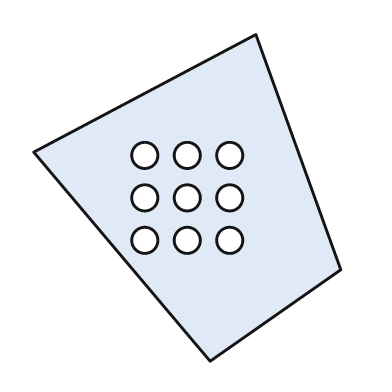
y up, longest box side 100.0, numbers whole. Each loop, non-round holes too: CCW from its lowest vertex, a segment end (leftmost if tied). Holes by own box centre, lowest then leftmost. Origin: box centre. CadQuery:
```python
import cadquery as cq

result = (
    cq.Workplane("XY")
    .moveTo(7.0, -50.0)
    .lineTo(47.0, -22.0)
    .lineTo(21.0, 50.0)
    .lineTo(-47.0, 14.0)
    .close()
    .moveTo(-13.0, -13.0)
    .circle(4.0)
    .moveTo(0.0, -13.0)
    .circle(4.0)
    .moveTo(13.0, -13.0)
    .circle(4.0)
    .moveTo(-13.0, 0.0)
    .circle(4.0)
    .moveTo(0.0, 0.0)
    .circle(4.0)
    .moveTo(13.0, 0.0)
    .circle(4.0)
    .moveTo(-13.0, 13.0)
    .circle(4.0)
    .moveTo(0.0, 13.0)
    .circle(4.0)
    .moveTo(13.0, 13.0)
    .circle(4.0)
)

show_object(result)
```